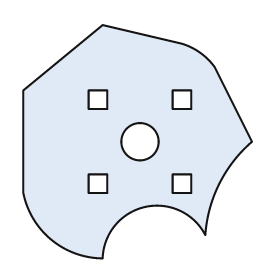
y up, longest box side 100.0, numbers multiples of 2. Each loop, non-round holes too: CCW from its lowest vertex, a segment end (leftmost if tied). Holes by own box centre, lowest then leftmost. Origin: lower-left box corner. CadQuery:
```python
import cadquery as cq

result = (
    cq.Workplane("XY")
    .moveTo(34.0, 0.0)
    .threePointArc((52.0, 22.0), (78.0, 10.0))
    .threePointArc((84.0, 32.0), (98.0, 50.0))
    .lineTo(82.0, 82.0)
    .threePointArc((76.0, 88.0), (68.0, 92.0))
    .lineTo(34.0, 100.0)
    .lineTo(0.0, 72.0)
    .lineTo(0.0, 28.0)
    .threePointArc((12.0, 8.0), (34.0, 0.0))
    .close()
    .moveTo(28.0, 28.0)
    .lineTo(36.0, 28.0)
    .lineTo(36.0, 36.0)
    .lineTo(28.0, 36.0)
    .close()
    .moveTo(64.0, 28.0)
    .lineTo(72.0, 28.0)
    .lineTo(72.0, 36.0)
    .lineTo(64.0, 36.0)
    .close()
    .moveTo(50.0, 50.0)
    .circle(8.0)
    .moveTo(28.0, 64.0)
    .lineTo(36.0, 64.0)
    .lineTo(36.0, 72.0)
    .lineTo(28.0, 72.0)
    .close()
    .moveTo(64.0, 64.0)
    .lineTo(72.0, 64.0)
    .lineTo(72.0, 72.0)
    .lineTo(64.0, 72.0)
    .close()
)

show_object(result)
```